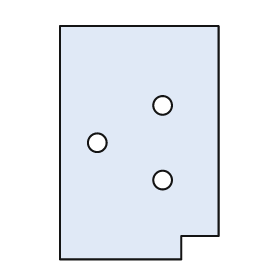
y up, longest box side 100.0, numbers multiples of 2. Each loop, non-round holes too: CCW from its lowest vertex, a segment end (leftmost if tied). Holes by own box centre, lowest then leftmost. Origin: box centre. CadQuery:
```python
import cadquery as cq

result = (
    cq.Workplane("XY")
    .moveTo(-34.0, -50.0)
    .lineTo(18.0, -50.0)
    .lineTo(18.0, -40.0)
    .lineTo(34.0, -40.0)
    .lineTo(34.0, 50.0)
    .lineTo(-34.0, 50.0)
    .close()
    .moveTo(10.0, -16.0)
    .circle(4.0)
    .moveTo(-18.0, 0.0)
    .circle(4.0)
    .moveTo(10.0, 16.0)
    .circle(4.0)
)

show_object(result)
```